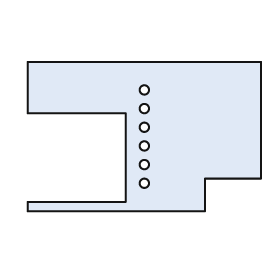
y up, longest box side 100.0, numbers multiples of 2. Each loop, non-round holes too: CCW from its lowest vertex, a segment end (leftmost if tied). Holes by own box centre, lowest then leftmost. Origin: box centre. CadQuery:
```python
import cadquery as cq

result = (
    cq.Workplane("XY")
    .moveTo(-50.0, -32.0)
    .lineTo(26.0, -32.0)
    .lineTo(26.0, -18.0)
    .lineTo(50.0, -18.0)
    .lineTo(50.0, 32.0)
    .lineTo(-50.0, 32.0)
    .lineTo(-50.0, 10.0)
    .lineTo(-8.0, 10.0)
    .lineTo(-8.0, -28.0)
    .lineTo(-50.0, -28.0)
    .close()
    .moveTo(0.0, -20.0)
    .circle(2.0)
    .moveTo(0.0, -12.0)
    .circle(2.0)
    .moveTo(0.0, -4.0)
    .circle(2.0)
    .moveTo(0.0, 4.0)
    .circle(2.0)
    .moveTo(0.0, 12.0)
    .circle(2.0)
    .moveTo(0.0, 20.0)
    .circle(2.0)
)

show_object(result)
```